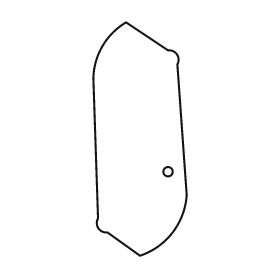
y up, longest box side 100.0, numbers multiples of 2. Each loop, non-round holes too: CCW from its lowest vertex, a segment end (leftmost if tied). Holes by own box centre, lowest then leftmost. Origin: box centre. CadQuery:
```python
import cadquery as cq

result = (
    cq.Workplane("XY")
    .moveTo(0.0, -50.0)
    .threePointArc((14.0, -40.0), (20.0, -24.0))
    .lineTo(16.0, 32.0)
    .threePointArc((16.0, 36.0), (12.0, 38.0))
    .lineTo(-6.0, 50.0)
    .threePointArc((-16.0, 40.0), (-20.0, 26.0))
    .lineTo(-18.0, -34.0)
    .threePointArc((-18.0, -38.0), (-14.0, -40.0))
    .close()
    .moveTo(12.0, -14.0)
    .circle(2.0)
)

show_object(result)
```